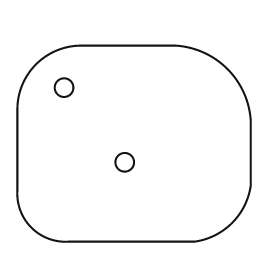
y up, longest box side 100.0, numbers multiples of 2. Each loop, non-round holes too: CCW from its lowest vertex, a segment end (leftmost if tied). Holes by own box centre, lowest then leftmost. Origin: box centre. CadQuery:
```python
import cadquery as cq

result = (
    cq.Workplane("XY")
    .moveTo(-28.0, -42.0)
    .lineTo(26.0, -42.0)
    .threePointArc((42.0, -34.0), (50.0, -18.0))
    .lineTo(50.0, 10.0)
    .threePointArc((40.0, 32.0), (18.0, 42.0))
    .lineTo(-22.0, 42.0)
    .threePointArc((-42.0, 34.0), (-50.0, 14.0))
    .lineTo(-50.0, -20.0)
    .threePointArc((-44.0, -36.0), (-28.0, -42.0))
    .close()
    .moveTo(-4.0, -8.0)
    .circle(4.0)
    .moveTo(-30.0, 24.0)
    .circle(4.0)
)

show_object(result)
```